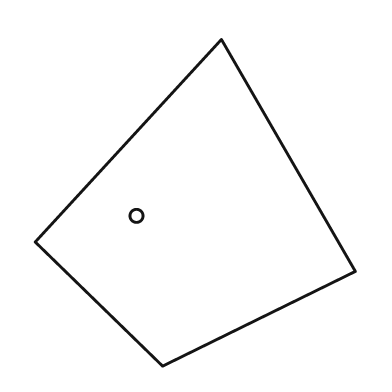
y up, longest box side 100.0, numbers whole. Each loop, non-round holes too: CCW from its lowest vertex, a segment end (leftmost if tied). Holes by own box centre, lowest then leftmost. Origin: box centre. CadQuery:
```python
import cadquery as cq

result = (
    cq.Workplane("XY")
    .moveTo(-10.0, -50.0)
    .lineTo(49.0, -21.0)
    .lineTo(8.0, 50.0)
    .lineTo(-49.0, -12.0)
    .close()
    .moveTo(-18.0, -4.0)
    .circle(2.0)
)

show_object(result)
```